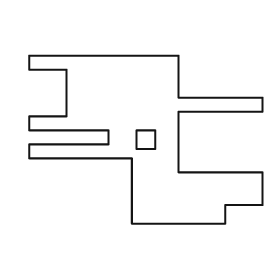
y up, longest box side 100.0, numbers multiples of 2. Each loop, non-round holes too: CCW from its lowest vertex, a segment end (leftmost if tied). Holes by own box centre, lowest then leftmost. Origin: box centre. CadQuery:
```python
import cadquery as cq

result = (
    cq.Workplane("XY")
    .moveTo(-6.0, -36.0)
    .lineTo(34.0, -36.0)
    .lineTo(34.0, -28.0)
    .lineTo(50.0, -28.0)
    .lineTo(50.0, -14.0)
    .lineTo(14.0, -14.0)
    .lineTo(14.0, 12.0)
    .lineTo(50.0, 12.0)
    .lineTo(50.0, 18.0)
    .lineTo(14.0, 18.0)
    .lineTo(14.0, 36.0)
    .lineTo(-50.0, 36.0)
    .lineTo(-50.0, 30.0)
    .lineTo(-34.0, 30.0)
    .lineTo(-34.0, 10.0)
    .lineTo(-50.0, 10.0)
    .lineTo(-50.0, 4.0)
    .lineTo(-16.0, 4.0)
    .lineTo(-16.0, -2.0)
    .lineTo(-50.0, -2.0)
    .lineTo(-50.0, -8.0)
    .lineTo(-6.0, -8.0)
    .close()
    .moveTo(-4.0, -4.0)
    .lineTo(4.0, -4.0)
    .lineTo(4.0, 4.0)
    .lineTo(-4.0, 4.0)
    .close()
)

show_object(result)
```